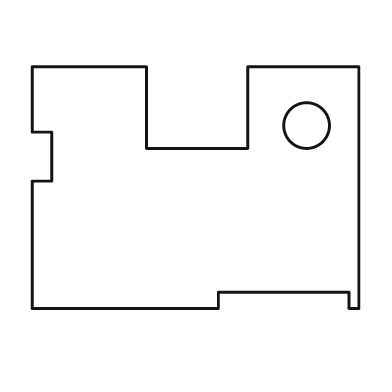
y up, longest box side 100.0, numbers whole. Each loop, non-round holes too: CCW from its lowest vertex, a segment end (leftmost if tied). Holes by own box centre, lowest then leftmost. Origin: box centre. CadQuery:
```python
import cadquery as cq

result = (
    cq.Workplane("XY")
    .moveTo(-50.0, -37.0)
    .lineTo(7.0, -37.0)
    .lineTo(7.0, -32.0)
    .lineTo(47.0, -32.0)
    .lineTo(47.0, -37.0)
    .lineTo(50.0, -37.0)
    .lineTo(50.0, 37.0)
    .lineTo(16.0, 37.0)
    .lineTo(16.0, 12.0)
    .lineTo(-15.0, 12.0)
    .lineTo(-15.0, 37.0)
    .lineTo(-50.0, 37.0)
    .lineTo(-50.0, 17.0)
    .lineTo(-44.0, 17.0)
    .lineTo(-44.0, 2.0)
    .lineTo(-50.0, 2.0)
    .close()
    .moveTo(34.0, 19.0)
    .circle(7.0)
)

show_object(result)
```